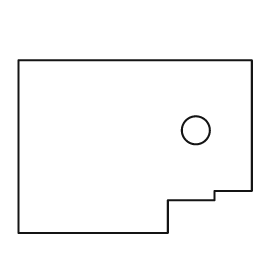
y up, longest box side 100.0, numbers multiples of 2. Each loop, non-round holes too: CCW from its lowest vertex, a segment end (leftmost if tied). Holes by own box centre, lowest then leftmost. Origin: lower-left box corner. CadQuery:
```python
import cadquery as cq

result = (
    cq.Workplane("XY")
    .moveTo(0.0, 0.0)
    .lineTo(64.0, 0.0)
    .lineTo(64.0, 14.0)
    .lineTo(84.0, 14.0)
    .lineTo(84.0, 18.0)
    .lineTo(100.0, 18.0)
    .lineTo(100.0, 74.0)
    .lineTo(0.0, 74.0)
    .close()
    .moveTo(76.0, 44.0)
    .circle(6.0)
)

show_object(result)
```